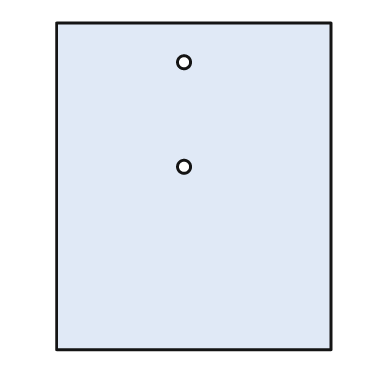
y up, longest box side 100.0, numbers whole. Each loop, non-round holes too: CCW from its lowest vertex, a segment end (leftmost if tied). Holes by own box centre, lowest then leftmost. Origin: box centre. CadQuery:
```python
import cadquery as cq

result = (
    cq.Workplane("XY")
    .moveTo(-42.0, -50.0)
    .lineTo(42.0, -50.0)
    .lineTo(42.0, 50.0)
    .lineTo(-42.0, 50.0)
    .close()
    .moveTo(-3.0, 6.0)
    .circle(2.0)
    .moveTo(-3.0, 38.0)
    .circle(2.0)
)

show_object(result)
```